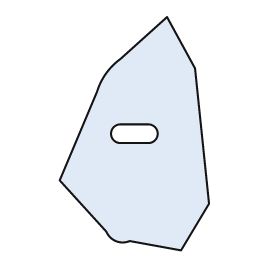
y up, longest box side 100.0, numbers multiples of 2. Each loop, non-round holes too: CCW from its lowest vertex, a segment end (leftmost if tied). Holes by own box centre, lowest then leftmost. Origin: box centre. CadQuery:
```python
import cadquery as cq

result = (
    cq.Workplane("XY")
    .moveTo(20.0, -50.0)
    .lineTo(32.0, -30.0)
    .lineTo(26.0, 28.0)
    .lineTo(14.0, 50.0)
    .lineTo(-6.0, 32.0)
    .threePointArc((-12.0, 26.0), (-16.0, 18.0))
    .lineTo(-32.0, -20.0)
    .lineTo(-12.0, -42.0)
    .threePointArc((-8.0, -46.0), (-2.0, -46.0))
    .close()
    .moveTo(-6.0, -4.0)
    .lineTo(6.0, -4.0)
    .threePointArc((10.0, 0.0), (6.0, 4.0))
    .lineTo(-6.0, 4.0)
    .threePointArc((-10.0, 0.0), (-6.0, -4.0))
    .close()
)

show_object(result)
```